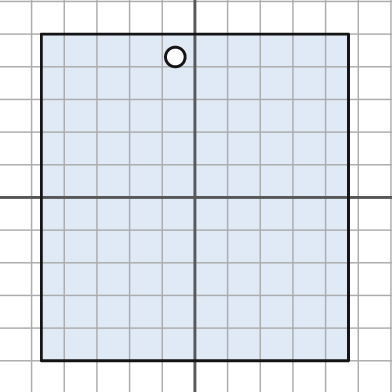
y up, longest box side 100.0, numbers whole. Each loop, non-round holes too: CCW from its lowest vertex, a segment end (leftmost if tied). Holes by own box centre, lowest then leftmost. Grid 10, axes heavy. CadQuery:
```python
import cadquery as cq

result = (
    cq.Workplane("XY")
    .moveTo(-47.0, -50.0)
    .lineTo(47.0, -50.0)
    .lineTo(47.0, 50.0)
    .lineTo(-47.0, 50.0)
    .close()
    .moveTo(-6.0, 43.0)
    .circle(3.0)
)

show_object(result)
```